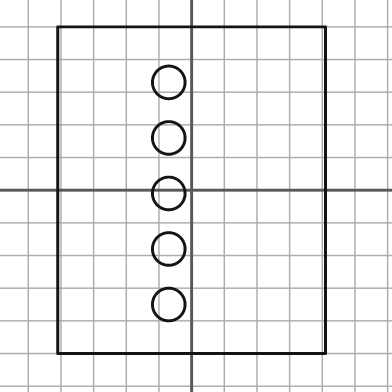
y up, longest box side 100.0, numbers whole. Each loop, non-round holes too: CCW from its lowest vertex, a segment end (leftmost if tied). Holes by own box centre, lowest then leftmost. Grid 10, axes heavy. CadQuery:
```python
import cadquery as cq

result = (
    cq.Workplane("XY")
    .moveTo(-41.0, -50.0)
    .lineTo(41.0, -50.0)
    .lineTo(41.0, 50.0)
    .lineTo(-41.0, 50.0)
    .close()
    .moveTo(-7.0, -35.0)
    .circle(5.0)
    .moveTo(-7.0, -18.0)
    .circle(5.0)
    .moveTo(-7.0, -1.0)
    .circle(5.0)
    .moveTo(-7.0, 16.0)
    .circle(5.0)
    .moveTo(-7.0, 33.0)
    .circle(5.0)
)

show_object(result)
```